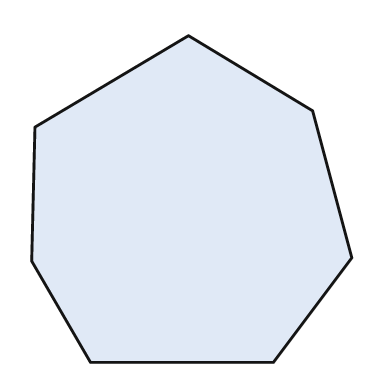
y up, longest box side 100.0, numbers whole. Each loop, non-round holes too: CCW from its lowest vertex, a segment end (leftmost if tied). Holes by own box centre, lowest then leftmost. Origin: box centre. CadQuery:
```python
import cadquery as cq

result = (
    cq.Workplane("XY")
    .moveTo(-31.0, -50.0)
    .lineTo(25.0, -50.0)
    .lineTo(49.0, -18.0)
    .lineTo(37.0, 27.0)
    .lineTo(-1.0, 50.0)
    .lineTo(-48.0, 22.0)
    .lineTo(-49.0, -19.0)
    .close()
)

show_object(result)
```